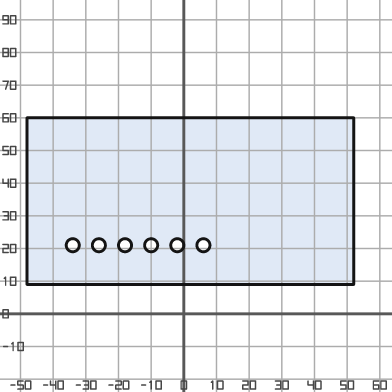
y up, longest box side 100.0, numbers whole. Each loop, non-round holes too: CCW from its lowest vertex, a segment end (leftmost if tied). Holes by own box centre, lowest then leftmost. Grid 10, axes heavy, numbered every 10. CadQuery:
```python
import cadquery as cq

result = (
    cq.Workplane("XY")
    .moveTo(-48.0, 9.0)
    .lineTo(52.0, 9.0)
    .lineTo(52.0, 60.0)
    .lineTo(-48.0, 60.0)
    .close()
    .moveTo(-34.0, 21.0)
    .circle(2.0)
    .moveTo(-26.0, 21.0)
    .circle(2.0)
    .moveTo(-18.0, 21.0)
    .circle(2.0)
    .moveTo(-10.0, 21.0)
    .circle(2.0)
    .moveTo(-2.0, 21.0)
    .circle(2.0)
    .moveTo(6.0, 21.0)
    .circle(2.0)
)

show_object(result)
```